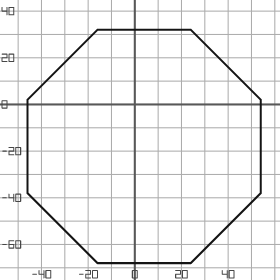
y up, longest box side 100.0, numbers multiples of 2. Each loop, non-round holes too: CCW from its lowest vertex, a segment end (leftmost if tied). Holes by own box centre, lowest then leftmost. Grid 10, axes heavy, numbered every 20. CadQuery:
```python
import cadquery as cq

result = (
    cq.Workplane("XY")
    .moveTo(-16.0, -68.0)
    .lineTo(24.0, -68.0)
    .lineTo(54.0, -38.0)
    .lineTo(54.0, 2.0)
    .lineTo(24.0, 32.0)
    .lineTo(-16.0, 32.0)
    .lineTo(-46.0, 2.0)
    .lineTo(-46.0, -38.0)
    .close()
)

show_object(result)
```